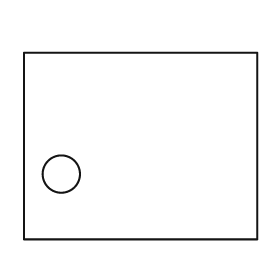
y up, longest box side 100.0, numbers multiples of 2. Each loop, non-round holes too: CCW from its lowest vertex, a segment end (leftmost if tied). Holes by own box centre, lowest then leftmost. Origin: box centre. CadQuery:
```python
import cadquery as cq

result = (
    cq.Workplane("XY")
    .moveTo(-50.0, -40.0)
    .lineTo(50.0, -40.0)
    .lineTo(50.0, 40.0)
    .lineTo(-50.0, 40.0)
    .close()
    .moveTo(-34.0, -12.0)
    .circle(8.0)
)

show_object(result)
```